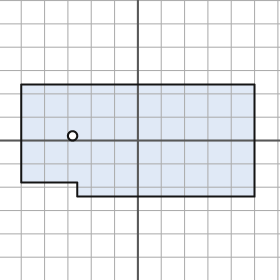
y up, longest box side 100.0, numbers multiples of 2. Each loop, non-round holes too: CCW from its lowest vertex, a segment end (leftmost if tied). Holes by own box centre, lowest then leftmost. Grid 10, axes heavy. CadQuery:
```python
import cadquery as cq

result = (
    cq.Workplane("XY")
    .moveTo(-26.0, -24.0)
    .lineTo(50.0, -24.0)
    .lineTo(50.0, 24.0)
    .lineTo(-50.0, 24.0)
    .lineTo(-50.0, -18.0)
    .lineTo(-26.0, -18.0)
    .close()
    .moveTo(-28.0, 2.0)
    .circle(2.0)
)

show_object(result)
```